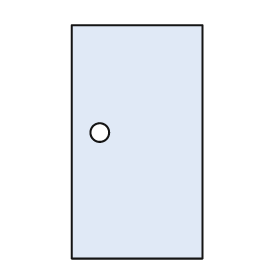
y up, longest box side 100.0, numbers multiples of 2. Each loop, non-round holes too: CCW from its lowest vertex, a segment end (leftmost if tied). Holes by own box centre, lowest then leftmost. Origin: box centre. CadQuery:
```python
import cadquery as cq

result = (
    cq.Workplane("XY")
    .moveTo(-28.0, -50.0)
    .lineTo(28.0, -50.0)
    .lineTo(28.0, 50.0)
    .lineTo(-28.0, 50.0)
    .close()
    .moveTo(-16.0, 4.0)
    .circle(4.0)
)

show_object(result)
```